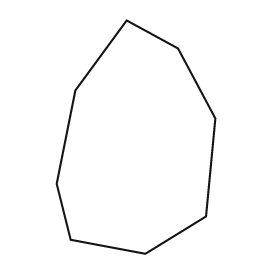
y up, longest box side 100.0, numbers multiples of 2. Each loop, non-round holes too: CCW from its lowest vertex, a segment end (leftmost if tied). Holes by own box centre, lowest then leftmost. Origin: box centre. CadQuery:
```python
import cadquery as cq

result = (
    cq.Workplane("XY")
    .moveTo(4.0, -50.0)
    .lineTo(30.0, -34.0)
    .lineTo(34.0, 8.0)
    .lineTo(18.0, 38.0)
    .lineTo(-4.0, 50.0)
    .lineTo(-26.0, 20.0)
    .lineTo(-34.0, -20.0)
    .lineTo(-28.0, -44.0)
    .close()
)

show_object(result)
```